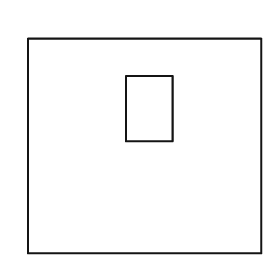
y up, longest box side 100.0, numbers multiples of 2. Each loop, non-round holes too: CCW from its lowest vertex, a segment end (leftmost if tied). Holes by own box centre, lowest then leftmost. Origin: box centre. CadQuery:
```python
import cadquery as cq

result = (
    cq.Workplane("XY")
    .moveTo(-50.0, -46.0)
    .lineTo(50.0, -46.0)
    .lineTo(50.0, 46.0)
    .lineTo(-50.0, 46.0)
    .close()
    .moveTo(-8.0, 2.0)
    .lineTo(12.0, 2.0)
    .lineTo(12.0, 30.0)
    .lineTo(-8.0, 30.0)
    .close()
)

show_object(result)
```